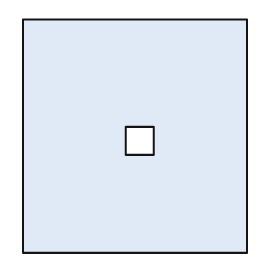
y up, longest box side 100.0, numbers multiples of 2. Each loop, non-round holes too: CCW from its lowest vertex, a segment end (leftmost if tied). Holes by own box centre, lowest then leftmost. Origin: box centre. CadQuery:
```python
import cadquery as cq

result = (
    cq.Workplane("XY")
    .moveTo(-48.0, -50.0)
    .lineTo(48.0, -50.0)
    .lineTo(48.0, 50.0)
    .lineTo(-48.0, 50.0)
    .close()
    .moveTo(-4.0, -8.0)
    .lineTo(8.0, -8.0)
    .lineTo(8.0, 4.0)
    .lineTo(-4.0, 4.0)
    .close()
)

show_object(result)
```